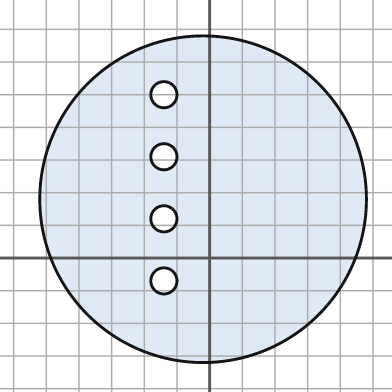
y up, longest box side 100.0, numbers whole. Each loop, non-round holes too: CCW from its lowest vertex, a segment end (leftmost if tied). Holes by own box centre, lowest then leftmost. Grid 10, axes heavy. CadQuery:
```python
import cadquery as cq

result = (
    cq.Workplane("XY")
    .moveTo(-2.0, 18.0)
    .circle(50.0)
    .moveTo(-14.0, -7.0)
    .circle(4.0)
    .moveTo(-14.0, 12.0)
    .circle(4.0)
    .moveTo(-14.0, 31.0)
    .circle(4.0)
    .moveTo(-14.0, 50.0)
    .circle(4.0)
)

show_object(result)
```